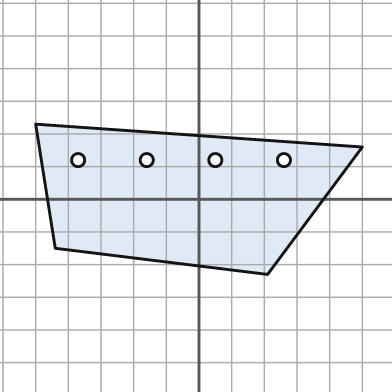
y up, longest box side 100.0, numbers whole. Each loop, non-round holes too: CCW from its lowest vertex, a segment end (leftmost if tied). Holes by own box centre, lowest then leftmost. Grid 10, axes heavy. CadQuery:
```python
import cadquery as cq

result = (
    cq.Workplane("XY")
    .moveTo(21.0, -23.0)
    .lineTo(50.0, 16.0)
    .lineTo(-50.0, 23.0)
    .lineTo(-44.0, -15.0)
    .close()
    .moveTo(-37.0, 12.0)
    .circle(2.0)
    .moveTo(-16.0, 12.0)
    .circle(2.0)
    .moveTo(5.0, 12.0)
    .circle(2.0)
    .moveTo(26.0, 12.0)
    .circle(2.0)
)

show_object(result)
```